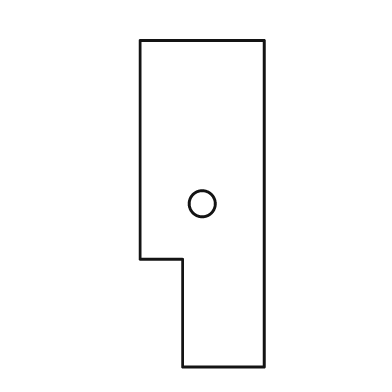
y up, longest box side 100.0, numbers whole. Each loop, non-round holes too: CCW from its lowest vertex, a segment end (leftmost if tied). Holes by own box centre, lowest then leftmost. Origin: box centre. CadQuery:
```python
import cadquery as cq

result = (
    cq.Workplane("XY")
    .moveTo(-6.0, -50.0)
    .lineTo(19.0, -50.0)
    .lineTo(19.0, 50.0)
    .lineTo(-19.0, 50.0)
    .lineTo(-19.0, -17.0)
    .lineTo(-6.0, -17.0)
    .close()
    .moveTo(0.0, 0.0)
    .circle(4.0)
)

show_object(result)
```